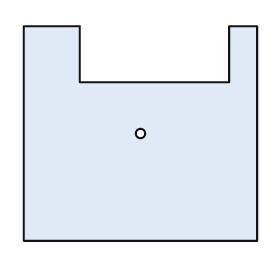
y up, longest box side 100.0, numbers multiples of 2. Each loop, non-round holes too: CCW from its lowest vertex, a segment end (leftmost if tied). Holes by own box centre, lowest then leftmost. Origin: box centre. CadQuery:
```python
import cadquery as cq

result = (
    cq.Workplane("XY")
    .moveTo(-50.0, -46.0)
    .lineTo(50.0, -46.0)
    .lineTo(50.0, 46.0)
    .lineTo(38.0, 46.0)
    .lineTo(38.0, 22.0)
    .lineTo(-26.0, 22.0)
    .lineTo(-26.0, 46.0)
    .lineTo(-50.0, 46.0)
    .close()
    .moveTo(0.0, 0.0)
    .circle(2.0)
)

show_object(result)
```